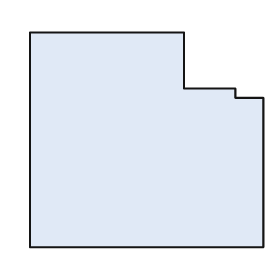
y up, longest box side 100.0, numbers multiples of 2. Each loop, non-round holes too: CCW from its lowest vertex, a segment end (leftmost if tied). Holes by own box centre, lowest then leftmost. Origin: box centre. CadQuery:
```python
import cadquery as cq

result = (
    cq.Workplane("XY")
    .moveTo(-50.0, -46.0)
    .lineTo(50.0, -46.0)
    .lineTo(50.0, 18.0)
    .lineTo(38.0, 18.0)
    .lineTo(38.0, 22.0)
    .lineTo(16.0, 22.0)
    .lineTo(16.0, 46.0)
    .lineTo(-50.0, 46.0)
    .close()
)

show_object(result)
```